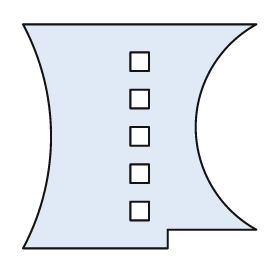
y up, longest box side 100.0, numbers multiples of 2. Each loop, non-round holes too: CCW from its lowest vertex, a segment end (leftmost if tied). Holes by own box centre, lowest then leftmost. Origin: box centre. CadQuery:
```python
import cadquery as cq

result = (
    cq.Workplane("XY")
    .moveTo(-50.0, -48.0)
    .lineTo(12.0, -48.0)
    .lineTo(12.0, -40.0)
    .lineTo(50.0, -40.0)
    .threePointArc((24.0, 4.0), (50.0, 48.0))
    .lineTo(-50.0, 48.0)
    .threePointArc((-38.0, 0.0), (-50.0, -48.0))
    .close()
    .moveTo(-4.0, -36.0)
    .lineTo(4.0, -36.0)
    .lineTo(4.0, -28.0)
    .lineTo(-4.0, -28.0)
    .close()
    .moveTo(-4.0, -20.0)
    .lineTo(4.0, -20.0)
    .lineTo(4.0, -12.0)
    .lineTo(-4.0, -12.0)
    .close()
    .moveTo(-4.0, -4.0)
    .lineTo(4.0, -4.0)
    .lineTo(4.0, 4.0)
    .lineTo(-4.0, 4.0)
    .close()
    .moveTo(-4.0, 12.0)
    .lineTo(4.0, 12.0)
    .lineTo(4.0, 20.0)
    .lineTo(-4.0, 20.0)
    .close()
    .moveTo(-4.0, 28.0)
    .lineTo(4.0, 28.0)
    .lineTo(4.0, 36.0)
    .lineTo(-4.0, 36.0)
    .close()
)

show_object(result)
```